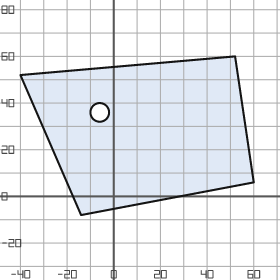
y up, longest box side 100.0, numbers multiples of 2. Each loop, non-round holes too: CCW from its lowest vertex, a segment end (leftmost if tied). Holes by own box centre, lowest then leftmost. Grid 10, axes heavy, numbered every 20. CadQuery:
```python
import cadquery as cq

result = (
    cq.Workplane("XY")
    .moveTo(-14.0, -8.0)
    .lineTo(60.0, 6.0)
    .lineTo(52.0, 60.0)
    .lineTo(-40.0, 52.0)
    .close()
    .moveTo(-6.0, 36.0)
    .circle(4.0)
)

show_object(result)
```